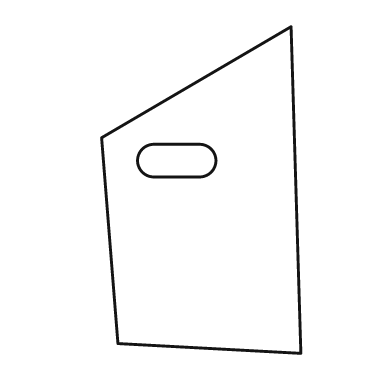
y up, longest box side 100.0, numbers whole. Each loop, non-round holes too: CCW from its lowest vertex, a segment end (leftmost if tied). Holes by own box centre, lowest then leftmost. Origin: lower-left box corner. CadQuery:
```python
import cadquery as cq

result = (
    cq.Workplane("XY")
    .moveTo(61.0, 0.0)
    .lineTo(58.0, 100.0)
    .lineTo(0.0, 66.0)
    .lineTo(5.0, 3.0)
    .close()
    .moveTo(16.0, 54.0)
    .lineTo(30.0, 54.0)
    .threePointArc((35.0, 59.0), (30.0, 64.0))
    .lineTo(16.0, 64.0)
    .threePointArc((11.0, 59.0), (16.0, 54.0))
    .close()
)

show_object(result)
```